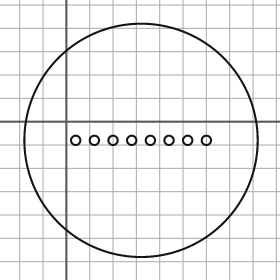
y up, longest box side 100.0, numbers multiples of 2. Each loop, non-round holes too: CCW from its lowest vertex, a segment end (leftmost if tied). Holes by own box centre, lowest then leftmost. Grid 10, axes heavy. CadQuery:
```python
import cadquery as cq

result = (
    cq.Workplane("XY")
    .moveTo(32.0, -8.0)
    .circle(50.0)
    .moveTo(4.0, -8.0)
    .circle(2.0)
    .moveTo(12.0, -8.0)
    .circle(2.0)
    .moveTo(20.0, -8.0)
    .circle(2.0)
    .moveTo(28.0, -8.0)
    .circle(2.0)
    .moveTo(36.0, -8.0)
    .circle(2.0)
    .moveTo(44.0, -8.0)
    .circle(2.0)
    .moveTo(52.0, -8.0)
    .circle(2.0)
    .moveTo(60.0, -8.0)
    .circle(2.0)
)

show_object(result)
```